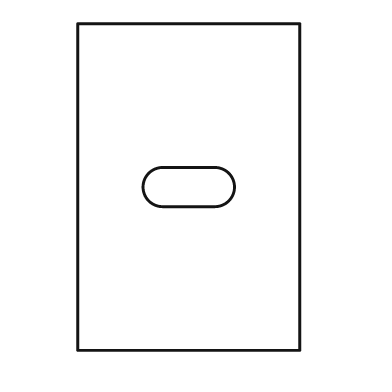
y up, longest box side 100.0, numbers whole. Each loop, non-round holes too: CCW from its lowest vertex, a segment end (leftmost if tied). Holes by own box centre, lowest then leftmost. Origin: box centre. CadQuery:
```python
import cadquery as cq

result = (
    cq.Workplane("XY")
    .moveTo(-34.0, -50.0)
    .lineTo(34.0, -50.0)
    .lineTo(34.0, 50.0)
    .lineTo(-34.0, 50.0)
    .close()
    .moveTo(-8.0, -6.0)
    .lineTo(8.0, -6.0)
    .threePointArc((14.0, 0.0), (8.0, 6.0))
    .lineTo(-8.0, 6.0)
    .threePointArc((-14.0, 0.0), (-8.0, -6.0))
    .close()
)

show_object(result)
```